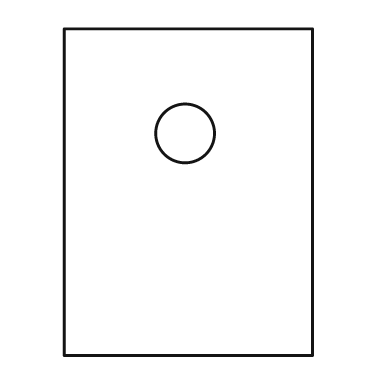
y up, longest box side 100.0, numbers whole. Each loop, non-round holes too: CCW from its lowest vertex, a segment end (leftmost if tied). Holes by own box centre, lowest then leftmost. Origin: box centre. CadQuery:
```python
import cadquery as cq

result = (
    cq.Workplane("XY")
    .moveTo(-38.0, -50.0)
    .lineTo(38.0, -50.0)
    .lineTo(38.0, 50.0)
    .lineTo(-38.0, 50.0)
    .close()
    .moveTo(-1.0, 18.0)
    .circle(9.0)
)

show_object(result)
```